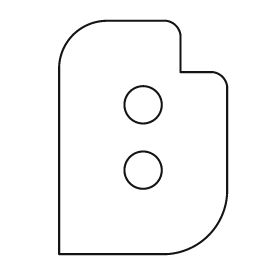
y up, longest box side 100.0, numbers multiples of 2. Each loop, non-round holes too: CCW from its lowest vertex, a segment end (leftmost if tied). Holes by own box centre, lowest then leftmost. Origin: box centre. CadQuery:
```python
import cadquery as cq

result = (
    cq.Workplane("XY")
    .moveTo(-36.0, -50.0)
    .lineTo(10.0, -50.0)
    .threePointArc((28.0, -42.0), (36.0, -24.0))
    .lineTo(36.0, 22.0)
    .threePointArc((34.0, 26.0), (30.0, 28.0))
    .lineTo(16.0, 28.0)
    .lineTo(16.0, 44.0)
    .threePointArc((14.0, 48.0), (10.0, 50.0))
    .lineTo(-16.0, 50.0)
    .threePointArc((-30.0, 44.0), (-36.0, 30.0))
    .close()
    .moveTo(0.0, -14.0)
    .circle(8.0)
    .moveTo(0.0, 14.0)
    .circle(8.0)
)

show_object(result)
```